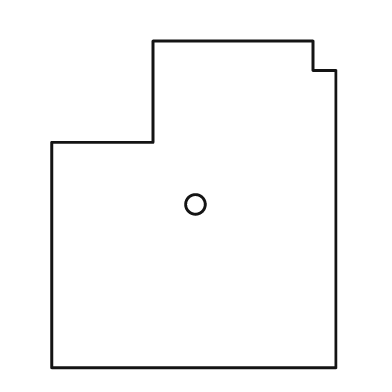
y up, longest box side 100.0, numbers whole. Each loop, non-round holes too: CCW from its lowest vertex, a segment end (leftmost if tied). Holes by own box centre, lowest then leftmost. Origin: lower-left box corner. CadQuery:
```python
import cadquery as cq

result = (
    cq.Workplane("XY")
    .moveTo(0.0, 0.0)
    .lineTo(87.0, 0.0)
    .lineTo(87.0, 91.0)
    .lineTo(80.0, 91.0)
    .lineTo(80.0, 100.0)
    .lineTo(31.0, 100.0)
    .lineTo(31.0, 69.0)
    .lineTo(0.0, 69.0)
    .close()
    .moveTo(44.0, 50.0)
    .circle(3.0)
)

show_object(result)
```